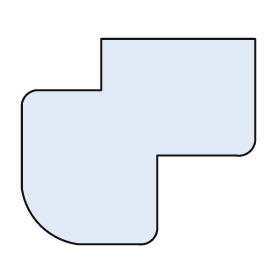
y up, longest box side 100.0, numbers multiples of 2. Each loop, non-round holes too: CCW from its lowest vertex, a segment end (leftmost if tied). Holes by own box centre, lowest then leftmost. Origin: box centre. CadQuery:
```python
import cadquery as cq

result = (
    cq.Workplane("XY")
    .moveTo(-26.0, -44.0)
    .lineTo(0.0, -44.0)
    .threePointArc((6.0, -42.0), (8.0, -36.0))
    .lineTo(8.0, -6.0)
    .lineTo(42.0, -6.0)
    .threePointArc((48.0, -4.0), (50.0, 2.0))
    .lineTo(50.0, 44.0)
    .lineTo(-16.0, 44.0)
    .lineTo(-16.0, 22.0)
    .lineTo(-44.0, 22.0)
    .threePointArc((-48.0, 20.0), (-50.0, 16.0))
    .lineTo(-50.0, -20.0)
    .threePointArc((-42.0, -36.0), (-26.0, -44.0))
    .close()
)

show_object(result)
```